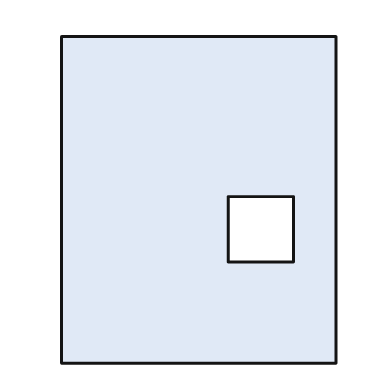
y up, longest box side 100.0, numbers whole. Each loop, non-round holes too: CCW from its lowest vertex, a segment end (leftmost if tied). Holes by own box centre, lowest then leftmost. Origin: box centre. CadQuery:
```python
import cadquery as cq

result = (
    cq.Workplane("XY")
    .moveTo(-42.0, -50.0)
    .lineTo(42.0, -50.0)
    .lineTo(42.0, 50.0)
    .lineTo(-42.0, 50.0)
    .close()
    .moveTo(9.0, -19.0)
    .lineTo(29.0, -19.0)
    .lineTo(29.0, 1.0)
    .lineTo(9.0, 1.0)
    .close()
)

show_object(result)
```